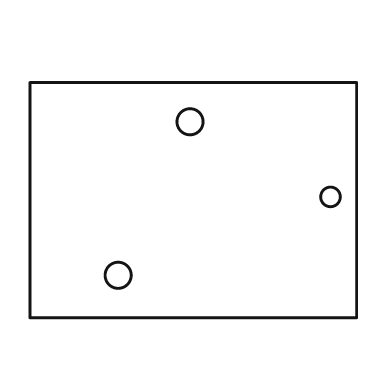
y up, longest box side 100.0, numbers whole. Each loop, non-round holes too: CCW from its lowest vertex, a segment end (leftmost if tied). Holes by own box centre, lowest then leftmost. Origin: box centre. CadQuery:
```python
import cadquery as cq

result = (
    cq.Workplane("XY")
    .moveTo(-50.0, -36.0)
    .lineTo(50.0, -36.0)
    .lineTo(50.0, 36.0)
    .lineTo(-50.0, 36.0)
    .close()
    .moveTo(-23.0, -23.0)
    .circle(4.0)
    .moveTo(42.0, 1.0)
    .circle(3.0)
    .moveTo(-1.0, 24.0)
    .circle(4.0)
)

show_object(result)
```